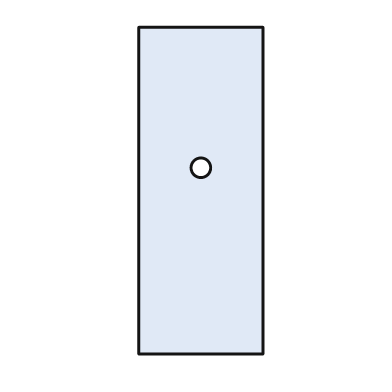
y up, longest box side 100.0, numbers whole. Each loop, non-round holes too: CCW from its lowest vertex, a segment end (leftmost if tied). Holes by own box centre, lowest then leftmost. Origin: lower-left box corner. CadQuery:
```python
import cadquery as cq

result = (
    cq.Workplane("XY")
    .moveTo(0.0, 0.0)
    .lineTo(38.0, 0.0)
    .lineTo(38.0, 100.0)
    .lineTo(0.0, 100.0)
    .close()
    .moveTo(19.0, 57.0)
    .circle(3.0)
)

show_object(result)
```